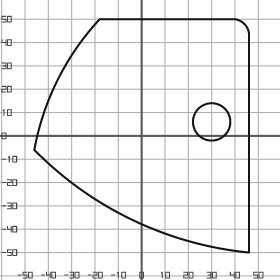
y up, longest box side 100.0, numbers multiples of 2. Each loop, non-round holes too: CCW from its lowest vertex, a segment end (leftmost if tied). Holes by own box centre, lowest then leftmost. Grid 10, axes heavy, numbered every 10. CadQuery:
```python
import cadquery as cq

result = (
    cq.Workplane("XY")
    .moveTo(46.0, -50.0)
    .lineTo(46.0, 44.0)
    .threePointArc((44.0, 48.0), (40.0, 50.0))
    .lineTo(-18.0, 50.0)
    .threePointArc((-36.0, 24.0), (-46.0, -6.0))
    .threePointArc((-4.0, -36.0), (46.0, -50.0))
    .close()
    .moveTo(30.0, 6.0)
    .circle(8.0)
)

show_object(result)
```